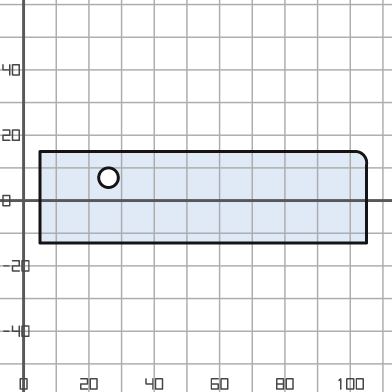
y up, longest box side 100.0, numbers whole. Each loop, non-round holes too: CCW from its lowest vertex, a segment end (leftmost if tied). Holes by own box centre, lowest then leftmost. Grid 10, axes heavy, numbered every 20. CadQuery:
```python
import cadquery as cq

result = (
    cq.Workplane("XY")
    .moveTo(5.0, -13.0)
    .lineTo(105.0, -13.0)
    .lineTo(105.0, 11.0)
    .threePointArc((104.0, 14.0), (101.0, 15.0))
    .lineTo(5.0, 15.0)
    .close()
    .moveTo(26.0, 7.0)
    .circle(3.0)
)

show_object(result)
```